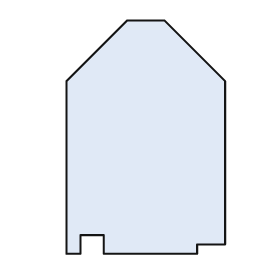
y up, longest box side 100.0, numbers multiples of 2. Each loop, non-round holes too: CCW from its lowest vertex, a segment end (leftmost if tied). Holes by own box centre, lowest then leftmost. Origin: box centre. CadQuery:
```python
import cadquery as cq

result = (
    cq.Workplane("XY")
    .moveTo(-34.0, -50.0)
    .lineTo(-28.0, -50.0)
    .lineTo(-28.0, -42.0)
    .lineTo(-18.0, -42.0)
    .lineTo(-18.0, -50.0)
    .lineTo(22.0, -50.0)
    .lineTo(22.0, -46.0)
    .lineTo(34.0, -46.0)
    .lineTo(34.0, 24.0)
    .lineTo(8.0, 50.0)
    .lineTo(-8.0, 50.0)
    .lineTo(-34.0, 24.0)
    .close()
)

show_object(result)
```